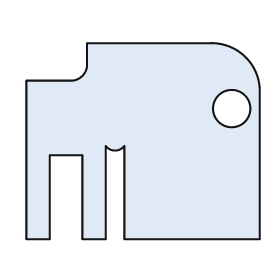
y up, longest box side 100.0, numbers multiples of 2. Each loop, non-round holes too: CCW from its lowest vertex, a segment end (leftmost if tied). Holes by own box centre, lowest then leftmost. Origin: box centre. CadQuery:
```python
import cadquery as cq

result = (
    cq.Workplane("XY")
    .moveTo(-50.0, -42.0)
    .lineTo(-40.0, -42.0)
    .lineTo(-40.0, -6.0)
    .lineTo(-26.0, -6.0)
    .lineTo(-26.0, -42.0)
    .lineTo(-16.0, -42.0)
    .lineTo(-16.0, -2.0)
    .threePointArc((-12.0, -4.0), (-8.0, -2.0))
    .lineTo(-8.0, -42.0)
    .lineTo(50.0, -42.0)
    .lineTo(50.0, 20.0)
    .threePointArc((44.0, 36.0), (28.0, 42.0))
    .lineTo(-24.0, 42.0)
    .lineTo(-24.0, 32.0)
    .threePointArc((-26.0, 28.0), (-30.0, 26.0))
    .lineTo(-50.0, 26.0)
    .close()
    .moveTo(38.0, 14.0)
    .circle(8.0)
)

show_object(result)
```